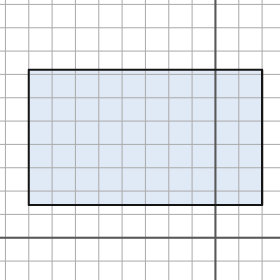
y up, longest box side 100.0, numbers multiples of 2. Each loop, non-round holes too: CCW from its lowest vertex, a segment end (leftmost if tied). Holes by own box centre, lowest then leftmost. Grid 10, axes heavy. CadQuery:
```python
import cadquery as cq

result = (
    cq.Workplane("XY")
    .moveTo(-80.0, 14.0)
    .lineTo(20.0, 14.0)
    .lineTo(20.0, 72.0)
    .lineTo(-80.0, 72.0)
    .close()
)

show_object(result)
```